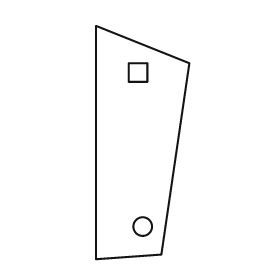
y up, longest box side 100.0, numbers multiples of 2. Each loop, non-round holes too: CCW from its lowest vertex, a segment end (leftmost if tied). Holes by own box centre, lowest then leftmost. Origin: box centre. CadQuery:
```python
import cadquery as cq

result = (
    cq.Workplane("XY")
    .moveTo(-20.0, -50.0)
    .lineTo(8.0, -48.0)
    .lineTo(20.0, 34.0)
    .lineTo(-20.0, 50.0)
    .close()
    .moveTo(0.0, -36.0)
    .circle(4.0)
    .moveTo(-6.0, 26.0)
    .lineTo(2.0, 26.0)
    .lineTo(2.0, 34.0)
    .lineTo(-6.0, 34.0)
    .close()
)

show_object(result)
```